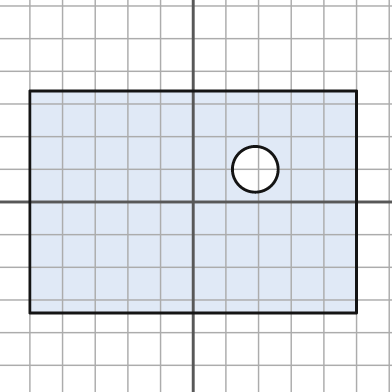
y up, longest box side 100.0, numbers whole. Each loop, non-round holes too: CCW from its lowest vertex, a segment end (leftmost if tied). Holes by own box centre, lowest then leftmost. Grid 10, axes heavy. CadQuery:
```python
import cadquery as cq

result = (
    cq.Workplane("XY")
    .moveTo(-50.0, -34.0)
    .lineTo(50.0, -34.0)
    .lineTo(50.0, 34.0)
    .lineTo(-50.0, 34.0)
    .close()
    .moveTo(19.0, 10.0)
    .circle(7.0)
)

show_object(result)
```